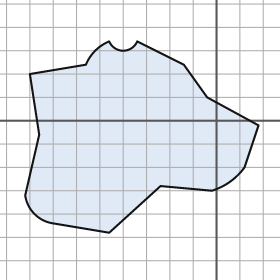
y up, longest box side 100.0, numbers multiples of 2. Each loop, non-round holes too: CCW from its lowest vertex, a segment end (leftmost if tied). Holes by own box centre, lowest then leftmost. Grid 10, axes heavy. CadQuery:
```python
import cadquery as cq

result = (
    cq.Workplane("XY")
    .moveTo(-46.0, -48.0)
    .lineTo(-24.0, -28.0)
    .lineTo(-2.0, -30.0)
    .threePointArc((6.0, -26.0), (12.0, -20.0))
    .lineTo(18.0, -2.0)
    .lineTo(-4.0, 10.0)
    .lineTo(-14.0, 24.0)
    .lineTo(-34.0, 34.0)
    .threePointArc((-40.0, 30.0), (-46.0, 34.0))
    .threePointArc((-52.0, 30.0), (-56.0, 24.0))
    .lineTo(-80.0, 20.0)
    .lineTo(-76.0, -6.0)
    .lineTo(-82.0, -32.0)
    .threePointArc((-78.0, -40.0), (-70.0, -44.0))
    .close()
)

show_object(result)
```